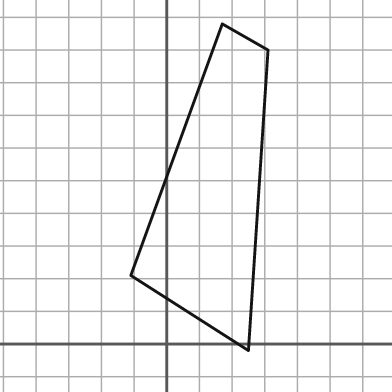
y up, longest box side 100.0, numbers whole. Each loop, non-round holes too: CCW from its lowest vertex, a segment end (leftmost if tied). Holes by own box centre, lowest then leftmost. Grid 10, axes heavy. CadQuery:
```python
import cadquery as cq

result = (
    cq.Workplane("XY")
    .moveTo(25.0, -2.0)
    .lineTo(31.0, 90.0)
    .lineTo(17.0, 98.0)
    .lineTo(-11.0, 21.0)
    .close()
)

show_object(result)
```